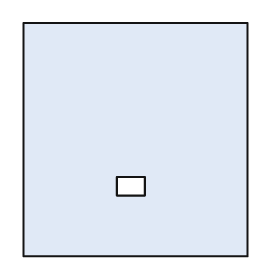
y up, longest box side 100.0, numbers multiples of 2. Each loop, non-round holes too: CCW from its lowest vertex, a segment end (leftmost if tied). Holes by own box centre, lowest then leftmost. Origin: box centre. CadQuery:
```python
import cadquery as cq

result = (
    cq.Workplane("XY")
    .moveTo(-48.0, -50.0)
    .lineTo(48.0, -50.0)
    .lineTo(48.0, 50.0)
    .lineTo(-48.0, 50.0)
    .close()
    .moveTo(-8.0, -24.0)
    .lineTo(4.0, -24.0)
    .lineTo(4.0, -16.0)
    .lineTo(-8.0, -16.0)
    .close()
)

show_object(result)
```